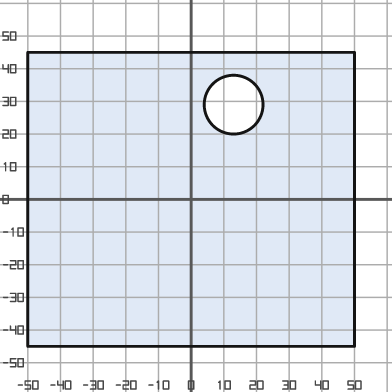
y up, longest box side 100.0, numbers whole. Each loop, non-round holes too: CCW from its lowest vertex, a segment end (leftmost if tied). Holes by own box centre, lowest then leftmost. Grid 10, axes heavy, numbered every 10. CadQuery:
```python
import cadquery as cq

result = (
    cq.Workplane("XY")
    .moveTo(-50.0, -45.0)
    .lineTo(50.0, -45.0)
    .lineTo(50.0, 45.0)
    .lineTo(-50.0, 45.0)
    .close()
    .moveTo(13.0, 29.0)
    .circle(9.0)
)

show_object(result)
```